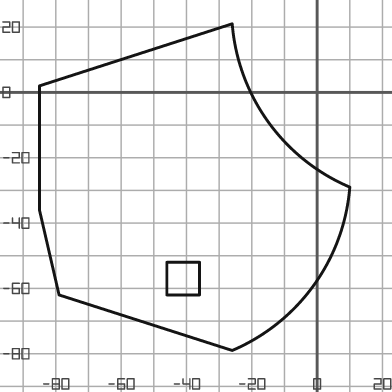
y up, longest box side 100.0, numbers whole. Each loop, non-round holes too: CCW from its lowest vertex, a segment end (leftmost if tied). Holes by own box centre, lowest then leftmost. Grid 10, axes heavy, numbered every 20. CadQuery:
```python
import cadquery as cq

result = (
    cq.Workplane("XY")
    .moveTo(-26.0, -79.0)
    .threePointArc((-1.0, -59.0), (10.0, -29.0))
    .threePointArc((-15.0, -9.0), (-26.0, 21.0))
    .lineTo(-85.0, 2.0)
    .lineTo(-85.0, -36.0)
    .lineTo(-79.0, -62.0)
    .close()
    .moveTo(-46.0, -62.0)
    .lineTo(-36.0, -62.0)
    .lineTo(-36.0, -52.0)
    .lineTo(-46.0, -52.0)
    .close()
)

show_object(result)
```